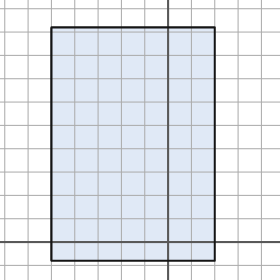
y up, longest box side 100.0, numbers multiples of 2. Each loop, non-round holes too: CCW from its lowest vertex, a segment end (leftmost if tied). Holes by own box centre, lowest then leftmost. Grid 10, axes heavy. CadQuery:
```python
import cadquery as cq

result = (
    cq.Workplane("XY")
    .moveTo(-50.0, -8.0)
    .lineTo(20.0, -8.0)
    .lineTo(20.0, 92.0)
    .lineTo(-50.0, 92.0)
    .close()
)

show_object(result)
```